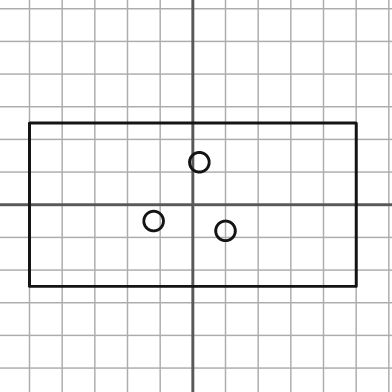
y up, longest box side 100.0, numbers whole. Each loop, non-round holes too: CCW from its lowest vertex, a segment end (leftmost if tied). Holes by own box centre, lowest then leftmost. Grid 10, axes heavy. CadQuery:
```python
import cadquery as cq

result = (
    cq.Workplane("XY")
    .moveTo(-50.0, -25.0)
    .lineTo(50.0, -25.0)
    .lineTo(50.0, 25.0)
    .lineTo(-50.0, 25.0)
    .close()
    .moveTo(10.0, -8.0)
    .circle(3.0)
    .moveTo(-12.0, -5.0)
    .circle(3.0)
    .moveTo(2.0, 13.0)
    .circle(3.0)
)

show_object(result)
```